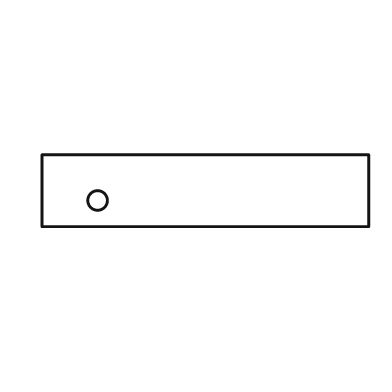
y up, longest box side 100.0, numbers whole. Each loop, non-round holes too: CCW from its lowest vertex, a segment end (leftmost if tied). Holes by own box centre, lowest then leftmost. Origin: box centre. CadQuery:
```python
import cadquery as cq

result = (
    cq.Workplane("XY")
    .moveTo(-50.0, -11.0)
    .lineTo(50.0, -11.0)
    .lineTo(50.0, 11.0)
    .lineTo(-50.0, 11.0)
    .close()
    .moveTo(-33.0, -3.0)
    .circle(3.0)
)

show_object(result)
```